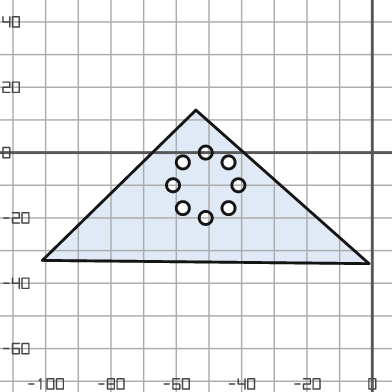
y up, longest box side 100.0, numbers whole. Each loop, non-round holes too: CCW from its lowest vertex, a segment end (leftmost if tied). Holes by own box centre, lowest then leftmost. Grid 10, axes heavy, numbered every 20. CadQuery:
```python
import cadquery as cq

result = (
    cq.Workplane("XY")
    .moveTo(-1.0, -34.0)
    .lineTo(-54.0, 13.0)
    .lineTo(-101.0, -33.0)
    .close()
    .moveTo(-51.0, -20.0)
    .circle(2.0)
    .moveTo(-58.0, -17.0)
    .circle(2.0)
    .moveTo(-44.0, -17.0)
    .circle(2.0)
    .moveTo(-61.0, -10.0)
    .circle(2.0)
    .moveTo(-41.0, -10.0)
    .circle(2.0)
    .moveTo(-58.0, -3.0)
    .circle(2.0)
    .moveTo(-44.0, -3.0)
    .circle(2.0)
    .moveTo(-51.0, 0.0)
    .circle(2.0)
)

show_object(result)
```